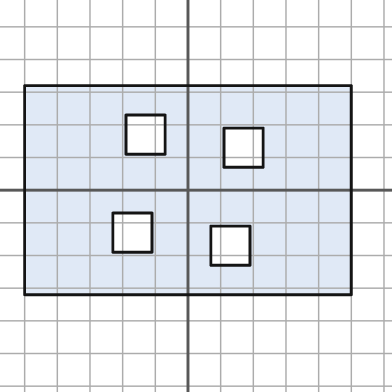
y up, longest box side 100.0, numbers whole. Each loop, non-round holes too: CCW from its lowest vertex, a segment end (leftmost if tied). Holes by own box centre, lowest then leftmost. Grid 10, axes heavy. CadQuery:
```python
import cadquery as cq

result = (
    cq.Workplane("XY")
    .moveTo(-50.0, -32.0)
    .lineTo(50.0, -32.0)
    .lineTo(50.0, 32.0)
    .lineTo(-50.0, 32.0)
    .close()
    .moveTo(7.0, -23.0)
    .lineTo(19.0, -23.0)
    .lineTo(19.0, -11.0)
    .lineTo(7.0, -11.0)
    .close()
    .moveTo(-23.0, -19.0)
    .lineTo(-11.0, -19.0)
    .lineTo(-11.0, -7.0)
    .lineTo(-23.0, -7.0)
    .close()
    .moveTo(11.0, 7.0)
    .lineTo(23.0, 7.0)
    .lineTo(23.0, 19.0)
    .lineTo(11.0, 19.0)
    .close()
    .moveTo(-19.0, 11.0)
    .lineTo(-7.0, 11.0)
    .lineTo(-7.0, 23.0)
    .lineTo(-19.0, 23.0)
    .close()
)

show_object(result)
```